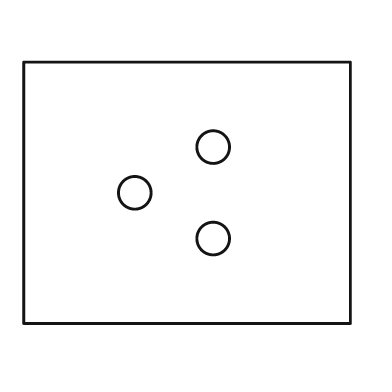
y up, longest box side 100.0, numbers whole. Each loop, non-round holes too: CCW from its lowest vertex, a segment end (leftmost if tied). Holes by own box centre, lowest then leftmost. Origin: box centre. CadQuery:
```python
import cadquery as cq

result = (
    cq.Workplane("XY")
    .moveTo(-50.0, -40.0)
    .lineTo(50.0, -40.0)
    .lineTo(50.0, 40.0)
    .lineTo(-50.0, 40.0)
    .close()
    .moveTo(8.0, -14.0)
    .circle(5.0)
    .moveTo(-16.0, 0.0)
    .circle(5.0)
    .moveTo(8.0, 14.0)
    .circle(5.0)
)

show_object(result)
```